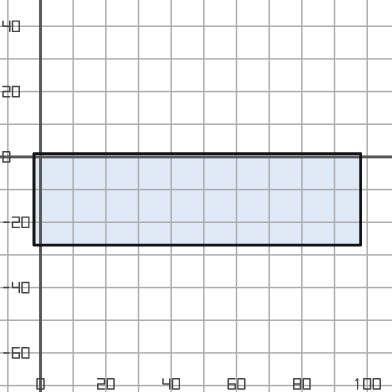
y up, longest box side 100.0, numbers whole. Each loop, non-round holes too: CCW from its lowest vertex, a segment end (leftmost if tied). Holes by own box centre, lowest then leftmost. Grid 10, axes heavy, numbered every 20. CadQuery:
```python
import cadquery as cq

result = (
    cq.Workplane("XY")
    .moveTo(-2.0, -27.0)
    .lineTo(98.0, -27.0)
    .lineTo(98.0, 1.0)
    .lineTo(-2.0, 1.0)
    .close()
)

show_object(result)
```